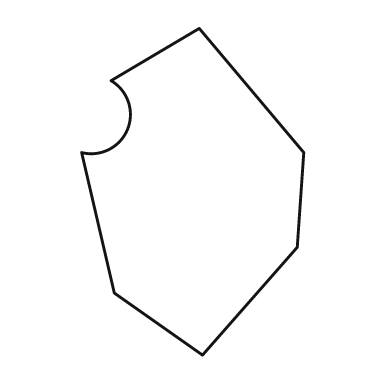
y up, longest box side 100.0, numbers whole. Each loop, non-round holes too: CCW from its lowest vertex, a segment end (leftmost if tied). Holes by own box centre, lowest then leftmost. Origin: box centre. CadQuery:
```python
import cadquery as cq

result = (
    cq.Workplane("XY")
    .moveTo(3.0, -50.0)
    .lineTo(32.0, -17.0)
    .lineTo(34.0, 12.0)
    .lineTo(2.0, 50.0)
    .lineTo(-25.0, 34.0)
    .threePointArc((-20.0, 19.0), (-34.0, 12.0))
    .lineTo(-24.0, -31.0)
    .close()
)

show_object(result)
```